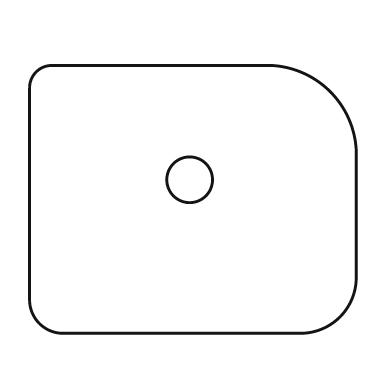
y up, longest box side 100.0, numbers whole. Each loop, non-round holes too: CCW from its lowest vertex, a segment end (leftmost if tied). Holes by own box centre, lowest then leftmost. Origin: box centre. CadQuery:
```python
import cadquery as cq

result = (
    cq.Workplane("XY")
    .moveTo(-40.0, -41.0)
    .lineTo(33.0, -41.0)
    .threePointArc((45.0, -36.0), (50.0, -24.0))
    .lineTo(50.0, 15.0)
    .threePointArc((42.0, 33.0), (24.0, 41.0))
    .lineTo(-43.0, 41.0)
    .threePointArc((-48.0, 39.0), (-50.0, 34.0))
    .lineTo(-50.0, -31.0)
    .threePointArc((-47.0, -38.0), (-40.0, -41.0))
    .close()
    .moveTo(-1.0, 6.0)
    .circle(7.0)
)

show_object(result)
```